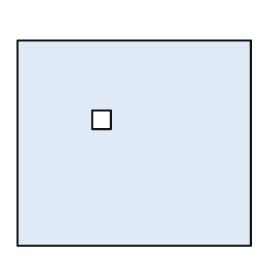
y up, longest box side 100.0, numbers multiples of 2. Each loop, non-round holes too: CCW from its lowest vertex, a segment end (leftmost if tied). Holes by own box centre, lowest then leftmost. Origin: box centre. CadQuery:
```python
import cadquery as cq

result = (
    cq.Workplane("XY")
    .moveTo(-50.0, -44.0)
    .lineTo(50.0, -44.0)
    .lineTo(50.0, 44.0)
    .lineTo(-50.0, 44.0)
    .close()
    .moveTo(-18.0, 6.0)
    .lineTo(-10.0, 6.0)
    .lineTo(-10.0, 14.0)
    .lineTo(-18.0, 14.0)
    .close()
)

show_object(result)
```